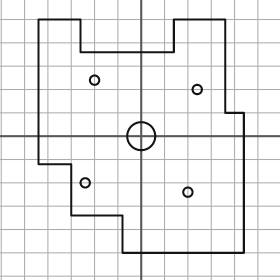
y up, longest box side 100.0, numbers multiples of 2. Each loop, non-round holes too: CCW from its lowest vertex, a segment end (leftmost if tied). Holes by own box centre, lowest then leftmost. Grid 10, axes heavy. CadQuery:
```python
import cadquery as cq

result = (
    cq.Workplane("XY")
    .moveTo(-8.0, -50.0)
    .lineTo(44.0, -50.0)
    .lineTo(44.0, 10.0)
    .lineTo(36.0, 10.0)
    .lineTo(36.0, 50.0)
    .lineTo(14.0, 50.0)
    .lineTo(14.0, 36.0)
    .lineTo(-26.0, 36.0)
    .lineTo(-26.0, 50.0)
    .lineTo(-44.0, 50.0)
    .lineTo(-44.0, -12.0)
    .lineTo(-30.0, -12.0)
    .lineTo(-30.0, -34.0)
    .lineTo(-8.0, -34.0)
    .close()
    .moveTo(20.0, -24.0)
    .circle(2.0)
    .moveTo(-24.0, -20.0)
    .circle(2.0)
    .moveTo(0.0, 0.0)
    .circle(6.0)
    .moveTo(24.0, 20.0)
    .circle(2.0)
    .moveTo(-20.0, 24.0)
    .circle(2.0)
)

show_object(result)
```